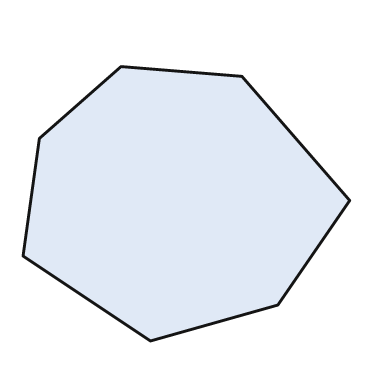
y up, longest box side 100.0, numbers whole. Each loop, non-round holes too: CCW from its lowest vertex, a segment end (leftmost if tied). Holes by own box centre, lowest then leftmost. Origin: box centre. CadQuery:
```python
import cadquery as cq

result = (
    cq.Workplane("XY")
    .moveTo(-11.0, -42.0)
    .lineTo(28.0, -31.0)
    .lineTo(50.0, 1.0)
    .lineTo(17.0, 39.0)
    .lineTo(-20.0, 42.0)
    .lineTo(-45.0, 20.0)
    .lineTo(-50.0, -16.0)
    .close()
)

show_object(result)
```